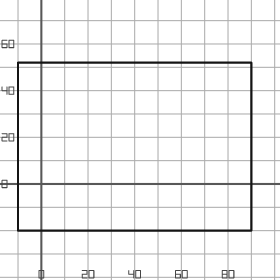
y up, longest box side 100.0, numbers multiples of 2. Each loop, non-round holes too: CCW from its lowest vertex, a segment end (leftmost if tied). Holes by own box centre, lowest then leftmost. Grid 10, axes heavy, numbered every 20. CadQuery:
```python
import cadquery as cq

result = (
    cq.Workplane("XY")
    .moveTo(-10.0, -20.0)
    .lineTo(90.0, -20.0)
    .lineTo(90.0, 52.0)
    .lineTo(-10.0, 52.0)
    .close()
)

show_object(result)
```